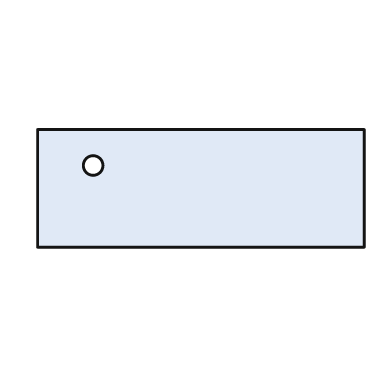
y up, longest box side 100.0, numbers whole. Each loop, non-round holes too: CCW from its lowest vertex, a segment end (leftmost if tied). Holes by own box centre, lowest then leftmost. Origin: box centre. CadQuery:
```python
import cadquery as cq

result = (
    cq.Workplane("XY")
    .moveTo(-50.0, -18.0)
    .lineTo(50.0, -18.0)
    .lineTo(50.0, 18.0)
    .lineTo(-50.0, 18.0)
    .close()
    .moveTo(-33.0, 7.0)
    .circle(3.0)
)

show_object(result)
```